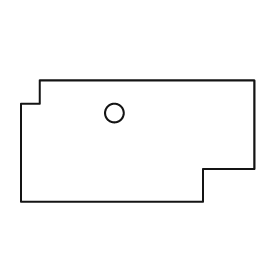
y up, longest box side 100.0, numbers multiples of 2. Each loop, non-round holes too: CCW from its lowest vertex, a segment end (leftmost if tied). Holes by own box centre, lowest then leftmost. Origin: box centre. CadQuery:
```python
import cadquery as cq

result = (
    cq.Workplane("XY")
    .moveTo(-50.0, -26.0)
    .lineTo(28.0, -26.0)
    .lineTo(28.0, -12.0)
    .lineTo(50.0, -12.0)
    .lineTo(50.0, 26.0)
    .lineTo(-42.0, 26.0)
    .lineTo(-42.0, 16.0)
    .lineTo(-50.0, 16.0)
    .close()
    .moveTo(-10.0, 12.0)
    .circle(4.0)
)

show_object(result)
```